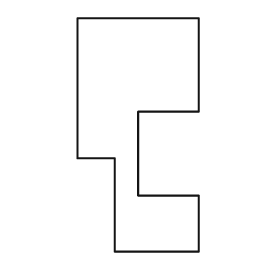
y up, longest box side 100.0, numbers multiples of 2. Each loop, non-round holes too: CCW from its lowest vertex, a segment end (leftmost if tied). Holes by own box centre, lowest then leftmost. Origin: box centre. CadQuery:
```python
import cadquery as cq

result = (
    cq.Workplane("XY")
    .moveTo(-10.0, -50.0)
    .lineTo(26.0, -50.0)
    .lineTo(26.0, -26.0)
    .lineTo(0.0, -26.0)
    .lineTo(0.0, 10.0)
    .lineTo(26.0, 10.0)
    .lineTo(26.0, 50.0)
    .lineTo(-26.0, 50.0)
    .lineTo(-26.0, -10.0)
    .lineTo(-10.0, -10.0)
    .close()
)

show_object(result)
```